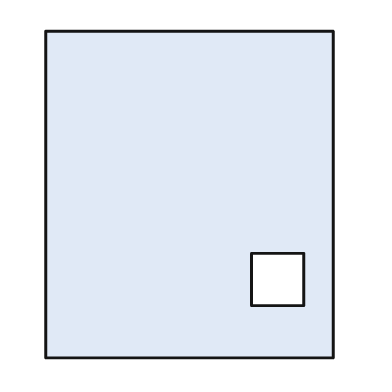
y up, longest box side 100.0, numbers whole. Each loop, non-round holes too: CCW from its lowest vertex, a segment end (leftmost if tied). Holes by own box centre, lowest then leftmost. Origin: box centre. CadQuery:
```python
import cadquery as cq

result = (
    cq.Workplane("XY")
    .moveTo(-44.0, -50.0)
    .lineTo(44.0, -50.0)
    .lineTo(44.0, 50.0)
    .lineTo(-44.0, 50.0)
    .close()
    .moveTo(19.0, -34.0)
    .lineTo(35.0, -34.0)
    .lineTo(35.0, -18.0)
    .lineTo(19.0, -18.0)
    .close()
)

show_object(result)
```